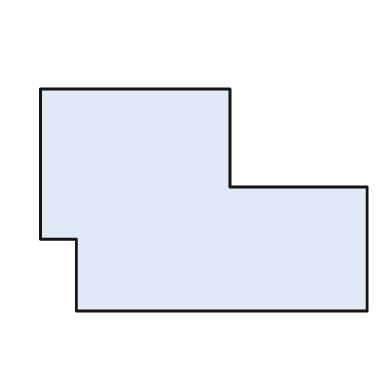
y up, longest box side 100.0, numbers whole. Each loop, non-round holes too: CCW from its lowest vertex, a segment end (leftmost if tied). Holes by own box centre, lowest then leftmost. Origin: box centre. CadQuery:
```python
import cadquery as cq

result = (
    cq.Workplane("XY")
    .moveTo(-39.0, -34.0)
    .lineTo(50.0, -34.0)
    .lineTo(50.0, 4.0)
    .lineTo(8.0, 4.0)
    .lineTo(8.0, 34.0)
    .lineTo(-50.0, 34.0)
    .lineTo(-50.0, -12.0)
    .lineTo(-39.0, -12.0)
    .close()
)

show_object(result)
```